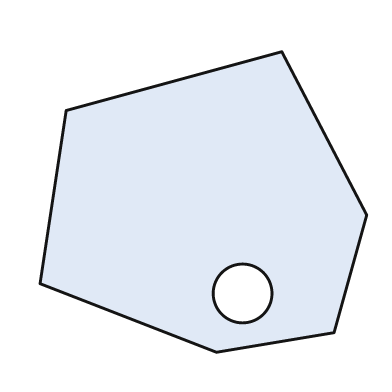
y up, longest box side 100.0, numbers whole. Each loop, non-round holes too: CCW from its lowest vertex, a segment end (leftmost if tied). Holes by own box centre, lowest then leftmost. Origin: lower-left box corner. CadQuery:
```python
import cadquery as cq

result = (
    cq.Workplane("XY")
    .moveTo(54.0, 0.0)
    .lineTo(90.0, 6.0)
    .lineTo(100.0, 42.0)
    .lineTo(74.0, 92.0)
    .lineTo(8.0, 74.0)
    .lineTo(0.0, 21.0)
    .close()
    .moveTo(62.0, 18.0)
    .circle(9.0)
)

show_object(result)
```